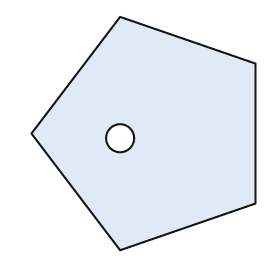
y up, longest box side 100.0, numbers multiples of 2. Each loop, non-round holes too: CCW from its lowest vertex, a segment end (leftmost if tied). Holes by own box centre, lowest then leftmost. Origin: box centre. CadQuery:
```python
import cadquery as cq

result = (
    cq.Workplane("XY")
    .moveTo(-10.0, -50.0)
    .lineTo(48.0, -30.0)
    .lineTo(48.0, 30.0)
    .lineTo(-10.0, 50.0)
    .lineTo(-48.0, 0.0)
    .close()
    .moveTo(-10.0, -2.0)
    .circle(6.0)
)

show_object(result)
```